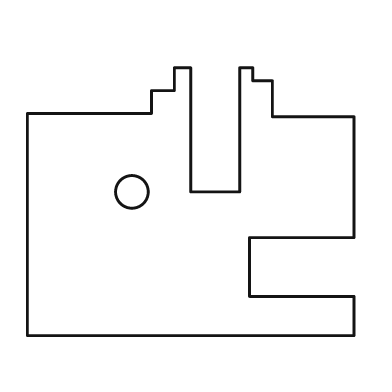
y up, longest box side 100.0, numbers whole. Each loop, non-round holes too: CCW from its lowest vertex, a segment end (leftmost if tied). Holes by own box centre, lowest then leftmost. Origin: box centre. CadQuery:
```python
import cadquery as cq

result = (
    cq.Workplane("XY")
    .moveTo(-50.0, -41.0)
    .lineTo(50.0, -41.0)
    .lineTo(50.0, -29.0)
    .lineTo(18.0, -29.0)
    .lineTo(18.0, -11.0)
    .lineTo(50.0, -11.0)
    .lineTo(50.0, 26.0)
    .lineTo(25.0, 26.0)
    .lineTo(25.0, 37.0)
    .lineTo(19.0, 37.0)
    .lineTo(19.0, 41.0)
    .lineTo(15.0, 41.0)
    .lineTo(15.0, 3.0)
    .lineTo(0.0, 3.0)
    .lineTo(0.0, 41.0)
    .lineTo(-5.0, 41.0)
    .lineTo(-5.0, 34.0)
    .lineTo(-12.0, 34.0)
    .lineTo(-12.0, 27.0)
    .lineTo(-50.0, 27.0)
    .close()
    .moveTo(-18.0, 3.0)
    .circle(5.0)
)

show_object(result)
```